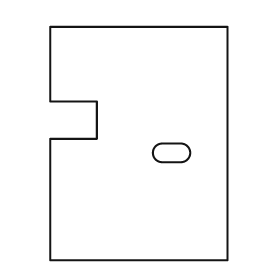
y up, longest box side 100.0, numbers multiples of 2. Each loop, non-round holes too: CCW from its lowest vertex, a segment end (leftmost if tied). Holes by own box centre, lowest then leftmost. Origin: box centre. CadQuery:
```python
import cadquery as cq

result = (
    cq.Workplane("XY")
    .moveTo(-38.0, -50.0)
    .lineTo(38.0, -50.0)
    .lineTo(38.0, 50.0)
    .lineTo(-38.0, 50.0)
    .lineTo(-38.0, 18.0)
    .lineTo(-18.0, 18.0)
    .lineTo(-18.0, 2.0)
    .lineTo(-38.0, 2.0)
    .close()
    .moveTo(10.0, -8.0)
    .lineTo(18.0, -8.0)
    .threePointArc((22.0, -4.0), (18.0, 0.0))
    .lineTo(10.0, 0.0)
    .threePointArc((6.0, -4.0), (10.0, -8.0))
    .close()
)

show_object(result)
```